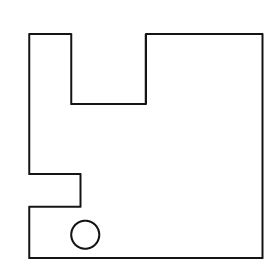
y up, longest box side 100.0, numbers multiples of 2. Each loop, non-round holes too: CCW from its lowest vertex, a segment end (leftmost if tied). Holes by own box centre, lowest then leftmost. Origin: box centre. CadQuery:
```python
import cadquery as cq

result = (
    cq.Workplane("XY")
    .moveTo(-50.0, -48.0)
    .lineTo(50.0, -48.0)
    .lineTo(50.0, 48.0)
    .lineTo(0.0, 48.0)
    .lineTo(0.0, 18.0)
    .lineTo(-32.0, 18.0)
    .lineTo(-32.0, 48.0)
    .lineTo(-50.0, 48.0)
    .lineTo(-50.0, -12.0)
    .lineTo(-28.0, -12.0)
    .lineTo(-28.0, -26.0)
    .lineTo(-50.0, -26.0)
    .close()
    .moveTo(-26.0, -38.0)
    .circle(6.0)
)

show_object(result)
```